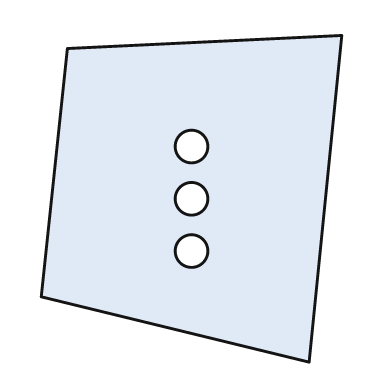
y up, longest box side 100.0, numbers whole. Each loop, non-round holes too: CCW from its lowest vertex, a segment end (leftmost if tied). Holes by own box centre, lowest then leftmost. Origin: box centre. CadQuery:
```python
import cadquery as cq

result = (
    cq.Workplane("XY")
    .moveTo(36.0, -50.0)
    .lineTo(46.0, 50.0)
    .lineTo(-38.0, 46.0)
    .lineTo(-46.0, -30.0)
    .close()
    .moveTo(0.0, -16.0)
    .circle(5.0)
    .moveTo(0.0, 0.0)
    .circle(5.0)
    .moveTo(0.0, 16.0)
    .circle(5.0)
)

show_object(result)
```